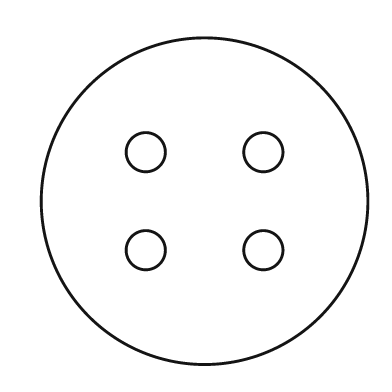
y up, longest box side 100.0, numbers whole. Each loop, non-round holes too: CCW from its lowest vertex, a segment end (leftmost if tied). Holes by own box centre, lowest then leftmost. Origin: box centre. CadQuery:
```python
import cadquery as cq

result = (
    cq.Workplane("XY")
    .moveTo(0.0, 0.0)
    .circle(50.0)
    .moveTo(-18.0, -15.0)
    .circle(6.0)
    .moveTo(18.0, -15.0)
    .circle(6.0)
    .moveTo(-18.0, 15.0)
    .circle(6.0)
    .moveTo(18.0, 15.0)
    .circle(6.0)
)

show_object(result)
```